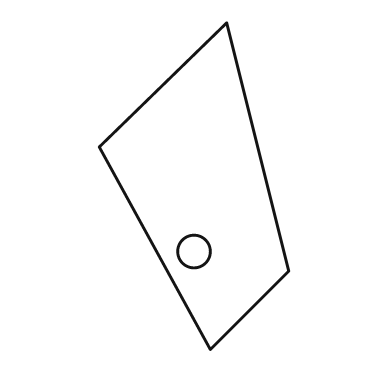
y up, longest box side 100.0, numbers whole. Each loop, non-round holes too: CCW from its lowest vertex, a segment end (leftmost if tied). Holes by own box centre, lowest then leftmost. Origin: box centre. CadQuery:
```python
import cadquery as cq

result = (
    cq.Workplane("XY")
    .moveTo(5.0, -50.0)
    .lineTo(29.0, -26.0)
    .lineTo(10.0, 50.0)
    .lineTo(-29.0, 12.0)
    .close()
    .moveTo(0.0, -20.0)
    .circle(5.0)
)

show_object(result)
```